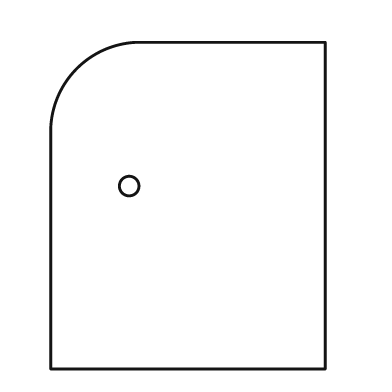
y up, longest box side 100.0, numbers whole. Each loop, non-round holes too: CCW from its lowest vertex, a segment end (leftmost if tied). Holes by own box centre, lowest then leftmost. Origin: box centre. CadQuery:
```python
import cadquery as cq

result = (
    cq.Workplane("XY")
    .moveTo(-42.0, -50.0)
    .lineTo(42.0, -50.0)
    .lineTo(42.0, 50.0)
    .lineTo(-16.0, 50.0)
    .threePointArc((-34.0, 42.0), (-42.0, 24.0))
    .close()
    .moveTo(-18.0, 6.0)
    .circle(3.0)
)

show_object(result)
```